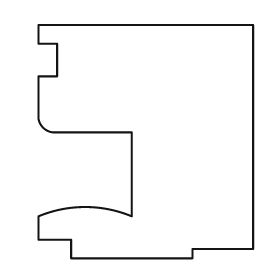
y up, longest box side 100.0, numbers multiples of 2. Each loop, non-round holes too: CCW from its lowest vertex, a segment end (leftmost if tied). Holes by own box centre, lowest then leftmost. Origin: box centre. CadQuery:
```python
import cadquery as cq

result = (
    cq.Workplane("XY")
    .moveTo(-32.0, -50.0)
    .lineTo(20.0, -50.0)
    .lineTo(20.0, -46.0)
    .lineTo(46.0, -46.0)
    .lineTo(46.0, 50.0)
    .lineTo(-46.0, 50.0)
    .lineTo(-46.0, 42.0)
    .lineTo(-38.0, 42.0)
    .lineTo(-38.0, 28.0)
    .lineTo(-46.0, 28.0)
    .lineTo(-46.0, 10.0)
    .threePointArc((-44.0, 6.0), (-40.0, 4.0))
    .lineTo(-6.0, 4.0)
    .lineTo(-6.0, -32.0)
    .threePointArc((-26.0, -28.0), (-46.0, -32.0))
    .lineTo(-46.0, -42.0)
    .lineTo(-32.0, -42.0)
    .close()
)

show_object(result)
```